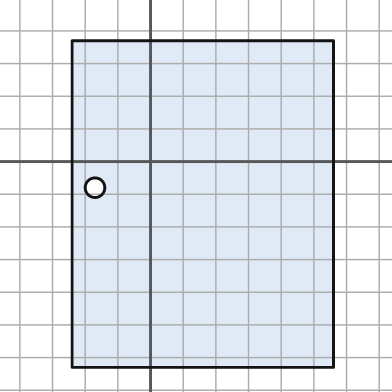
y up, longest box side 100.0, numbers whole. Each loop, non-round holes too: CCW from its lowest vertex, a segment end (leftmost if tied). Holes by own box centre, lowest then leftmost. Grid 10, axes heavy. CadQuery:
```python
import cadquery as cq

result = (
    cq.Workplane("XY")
    .moveTo(-24.0, -63.0)
    .lineTo(56.0, -63.0)
    .lineTo(56.0, 37.0)
    .lineTo(-24.0, 37.0)
    .close()
    .moveTo(-17.0, -8.0)
    .circle(3.0)
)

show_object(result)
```